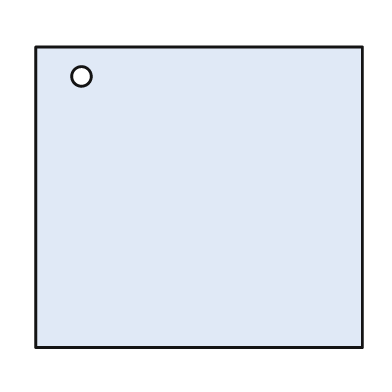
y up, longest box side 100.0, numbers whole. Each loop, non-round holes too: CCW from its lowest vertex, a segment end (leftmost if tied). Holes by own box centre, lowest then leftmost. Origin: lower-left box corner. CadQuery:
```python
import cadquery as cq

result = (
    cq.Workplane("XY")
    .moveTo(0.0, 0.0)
    .lineTo(100.0, 0.0)
    .lineTo(100.0, 92.0)
    .lineTo(0.0, 92.0)
    .close()
    .moveTo(14.0, 83.0)
    .circle(3.0)
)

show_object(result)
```